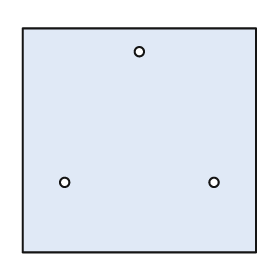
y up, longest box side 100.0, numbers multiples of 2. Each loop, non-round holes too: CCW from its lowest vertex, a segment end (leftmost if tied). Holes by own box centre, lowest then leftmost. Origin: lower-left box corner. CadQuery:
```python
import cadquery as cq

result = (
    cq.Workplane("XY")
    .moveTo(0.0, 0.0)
    .lineTo(100.0, 0.0)
    .lineTo(100.0, 96.0)
    .lineTo(0.0, 96.0)
    .close()
    .moveTo(18.0, 30.0)
    .circle(2.0)
    .moveTo(82.0, 30.0)
    .circle(2.0)
    .moveTo(50.0, 86.0)
    .circle(2.0)
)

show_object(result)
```